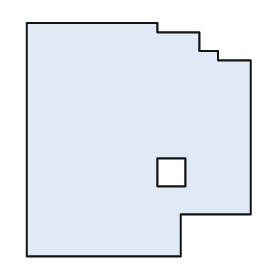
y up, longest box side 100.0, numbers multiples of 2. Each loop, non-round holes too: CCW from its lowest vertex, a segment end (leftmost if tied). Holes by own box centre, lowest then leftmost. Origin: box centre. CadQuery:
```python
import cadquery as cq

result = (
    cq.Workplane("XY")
    .moveTo(-48.0, -50.0)
    .lineTo(18.0, -50.0)
    .lineTo(18.0, -32.0)
    .lineTo(48.0, -32.0)
    .lineTo(48.0, 34.0)
    .lineTo(34.0, 34.0)
    .lineTo(34.0, 38.0)
    .lineTo(26.0, 38.0)
    .lineTo(26.0, 46.0)
    .lineTo(8.0, 46.0)
    .lineTo(8.0, 50.0)
    .lineTo(-48.0, 50.0)
    .close()
    .moveTo(8.0, -20.0)
    .lineTo(20.0, -20.0)
    .lineTo(20.0, -8.0)
    .lineTo(8.0, -8.0)
    .close()
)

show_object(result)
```